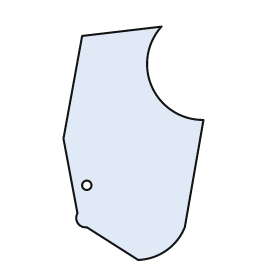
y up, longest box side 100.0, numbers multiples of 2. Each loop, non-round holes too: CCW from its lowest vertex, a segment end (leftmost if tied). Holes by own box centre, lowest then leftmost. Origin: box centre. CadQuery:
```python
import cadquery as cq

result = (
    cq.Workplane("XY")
    .moveTo(2.0, -50.0)
    .threePointArc((14.0, -46.0), (22.0, -36.0))
    .lineTo(30.0, 10.0)
    .threePointArc((8.0, 24.0), (12.0, 50.0))
    .lineTo(-22.0, 46.0)
    .lineTo(-30.0, 2.0)
    .lineTo(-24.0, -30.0)
    .threePointArc((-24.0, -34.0), (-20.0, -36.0))
    .close()
    .moveTo(-20.0, -18.0)
    .circle(2.0)
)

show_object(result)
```